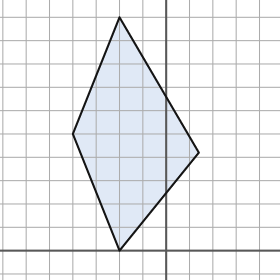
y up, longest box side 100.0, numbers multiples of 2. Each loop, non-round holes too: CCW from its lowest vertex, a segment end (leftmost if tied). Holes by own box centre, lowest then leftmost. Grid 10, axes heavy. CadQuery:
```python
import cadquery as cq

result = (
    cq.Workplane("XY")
    .moveTo(-20.0, 0.0)
    .lineTo(14.0, 42.0)
    .lineTo(-20.0, 100.0)
    .lineTo(-40.0, 50.0)
    .close()
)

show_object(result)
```